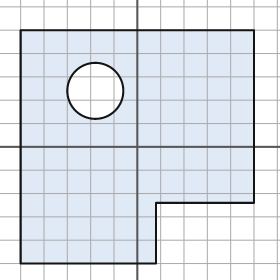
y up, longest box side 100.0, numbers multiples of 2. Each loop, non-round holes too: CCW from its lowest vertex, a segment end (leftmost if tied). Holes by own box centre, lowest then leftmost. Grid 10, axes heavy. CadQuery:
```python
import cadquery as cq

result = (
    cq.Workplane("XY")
    .moveTo(-50.0, -50.0)
    .lineTo(8.0, -50.0)
    .lineTo(8.0, -24.0)
    .lineTo(50.0, -24.0)
    .lineTo(50.0, 50.0)
    .lineTo(-50.0, 50.0)
    .close()
    .moveTo(-18.0, 24.0)
    .circle(12.0)
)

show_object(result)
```